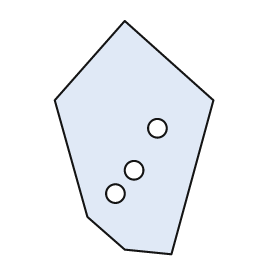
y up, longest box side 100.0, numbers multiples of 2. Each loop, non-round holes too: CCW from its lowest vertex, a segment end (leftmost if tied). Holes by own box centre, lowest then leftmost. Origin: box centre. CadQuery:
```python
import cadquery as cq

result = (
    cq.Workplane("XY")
    .moveTo(16.0, -50.0)
    .lineTo(34.0, 16.0)
    .lineTo(-4.0, 50.0)
    .lineTo(-34.0, 16.0)
    .lineTo(-20.0, -34.0)
    .lineTo(-4.0, -48.0)
    .close()
    .moveTo(-8.0, -24.0)
    .circle(4.0)
    .moveTo(0.0, -14.0)
    .circle(4.0)
    .moveTo(10.0, 4.0)
    .circle(4.0)
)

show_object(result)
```